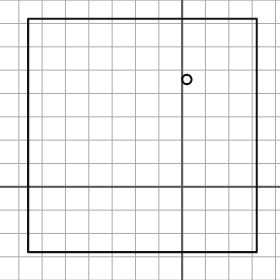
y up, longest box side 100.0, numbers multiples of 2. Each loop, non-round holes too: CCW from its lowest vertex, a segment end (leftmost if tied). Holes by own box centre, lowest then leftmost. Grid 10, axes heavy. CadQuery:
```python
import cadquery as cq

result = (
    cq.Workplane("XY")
    .moveTo(-66.0, -28.0)
    .lineTo(32.0, -28.0)
    .lineTo(32.0, 72.0)
    .lineTo(-66.0, 72.0)
    .close()
    .moveTo(2.0, 46.0)
    .circle(2.0)
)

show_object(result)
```